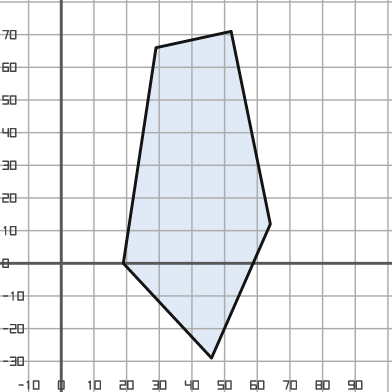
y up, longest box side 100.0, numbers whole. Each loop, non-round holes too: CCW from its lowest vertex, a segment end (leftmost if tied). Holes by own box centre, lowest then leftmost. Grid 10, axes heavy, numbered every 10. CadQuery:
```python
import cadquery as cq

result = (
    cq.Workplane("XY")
    .moveTo(46.0, -29.0)
    .lineTo(64.0, 12.0)
    .lineTo(52.0, 71.0)
    .lineTo(29.0, 66.0)
    .lineTo(19.0, 0.0)
    .close()
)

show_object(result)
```